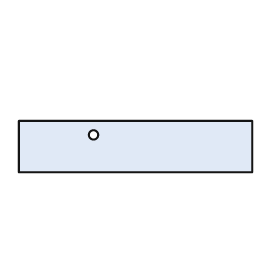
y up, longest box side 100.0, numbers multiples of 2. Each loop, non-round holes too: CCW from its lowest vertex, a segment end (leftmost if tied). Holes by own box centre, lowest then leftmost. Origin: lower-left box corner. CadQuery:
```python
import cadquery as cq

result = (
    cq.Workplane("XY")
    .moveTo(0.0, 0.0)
    .lineTo(100.0, 0.0)
    .lineTo(100.0, 22.0)
    .lineTo(0.0, 22.0)
    .close()
    .moveTo(32.0, 16.0)
    .circle(2.0)
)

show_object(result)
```